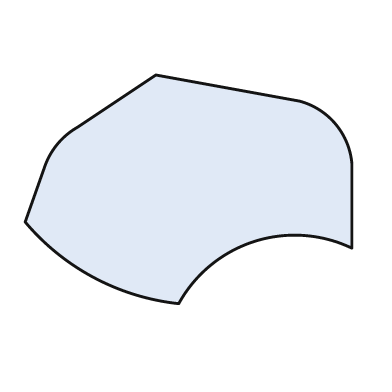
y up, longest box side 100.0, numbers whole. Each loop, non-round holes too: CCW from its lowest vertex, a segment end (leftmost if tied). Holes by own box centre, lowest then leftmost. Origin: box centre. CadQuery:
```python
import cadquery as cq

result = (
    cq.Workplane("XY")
    .moveTo(-3.0, -35.0)
    .threePointArc((20.0, -16.0), (50.0, -18.0))
    .lineTo(50.0, 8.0)
    .threePointArc((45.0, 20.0), (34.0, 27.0))
    .lineTo(-10.0, 35.0)
    .lineTo(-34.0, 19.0)
    .threePointArc((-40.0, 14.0), (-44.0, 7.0))
    .lineTo(-50.0, -10.0)
    .threePointArc((-29.0, -27.0), (-3.0, -35.0))
    .close()
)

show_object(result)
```